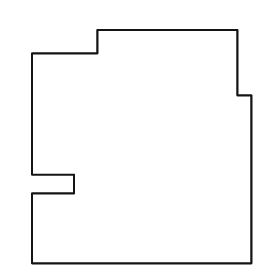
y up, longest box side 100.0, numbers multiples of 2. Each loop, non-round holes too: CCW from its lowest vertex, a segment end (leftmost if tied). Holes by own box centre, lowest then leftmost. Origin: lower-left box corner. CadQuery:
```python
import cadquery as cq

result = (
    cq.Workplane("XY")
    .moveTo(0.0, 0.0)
    .lineTo(94.0, 0.0)
    .lineTo(94.0, 72.0)
    .lineTo(88.0, 72.0)
    .lineTo(88.0, 100.0)
    .lineTo(28.0, 100.0)
    .lineTo(28.0, 90.0)
    .lineTo(0.0, 90.0)
    .lineTo(0.0, 38.0)
    .lineTo(18.0, 38.0)
    .lineTo(18.0, 30.0)
    .lineTo(0.0, 30.0)
    .close()
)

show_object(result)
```